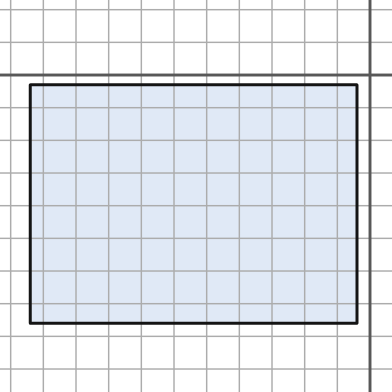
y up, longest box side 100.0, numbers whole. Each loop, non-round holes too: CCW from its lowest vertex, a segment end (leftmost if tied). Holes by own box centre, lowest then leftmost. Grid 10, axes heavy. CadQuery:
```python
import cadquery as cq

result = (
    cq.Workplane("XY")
    .moveTo(-104.0, -76.0)
    .lineTo(-4.0, -76.0)
    .lineTo(-4.0, -3.0)
    .lineTo(-104.0, -3.0)
    .close()
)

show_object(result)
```